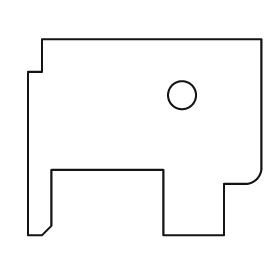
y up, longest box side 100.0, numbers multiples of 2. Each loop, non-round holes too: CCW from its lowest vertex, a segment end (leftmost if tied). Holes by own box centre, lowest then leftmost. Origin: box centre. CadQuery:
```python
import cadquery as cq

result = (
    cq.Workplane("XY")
    .moveTo(-50.0, -42.0)
    .lineTo(-44.0, -42.0)
    .lineTo(-40.0, -38.0)
    .lineTo(-40.0, -14.0)
    .lineTo(8.0, -14.0)
    .lineTo(8.0, -42.0)
    .lineTo(34.0, -42.0)
    .lineTo(34.0, -20.0)
    .lineTo(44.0, -20.0)
    .threePointArc((48.0, -18.0), (50.0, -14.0))
    .lineTo(50.0, 42.0)
    .lineTo(-44.0, 42.0)
    .lineTo(-44.0, 28.0)
    .lineTo(-50.0, 28.0)
    .close()
    .moveTo(16.0, 18.0)
    .circle(6.0)
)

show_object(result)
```